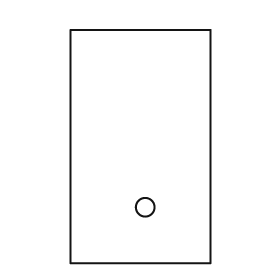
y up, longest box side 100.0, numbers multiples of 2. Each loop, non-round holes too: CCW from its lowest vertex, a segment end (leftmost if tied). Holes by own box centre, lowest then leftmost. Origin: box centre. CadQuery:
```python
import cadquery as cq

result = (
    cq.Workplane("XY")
    .moveTo(-30.0, -50.0)
    .lineTo(30.0, -50.0)
    .lineTo(30.0, 50.0)
    .lineTo(-30.0, 50.0)
    .close()
    .moveTo(2.0, -26.0)
    .circle(4.0)
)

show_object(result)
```